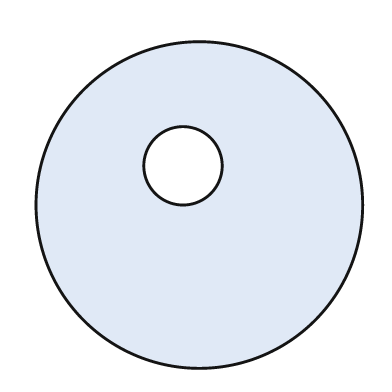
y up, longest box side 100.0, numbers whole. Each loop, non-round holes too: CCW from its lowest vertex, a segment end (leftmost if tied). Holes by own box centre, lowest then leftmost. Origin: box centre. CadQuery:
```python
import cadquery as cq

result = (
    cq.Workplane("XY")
    .moveTo(0.0, 0.0)
    .circle(50.0)
    .moveTo(-5.0, 12.0)
    .circle(12.0)
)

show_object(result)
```